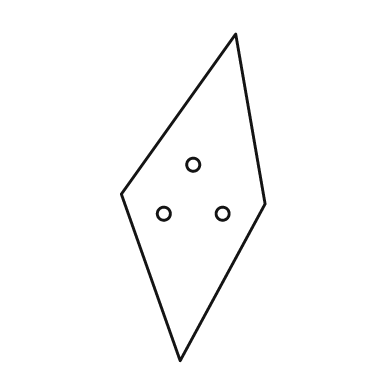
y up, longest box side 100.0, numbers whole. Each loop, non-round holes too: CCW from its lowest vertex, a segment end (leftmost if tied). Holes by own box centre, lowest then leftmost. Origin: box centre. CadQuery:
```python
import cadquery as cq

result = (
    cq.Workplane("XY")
    .moveTo(-4.0, -50.0)
    .lineTo(22.0, -2.0)
    .lineTo(13.0, 50.0)
    .lineTo(-22.0, 1.0)
    .close()
    .moveTo(-9.0, -5.0)
    .circle(2.0)
    .moveTo(9.0, -5.0)
    .circle(2.0)
    .moveTo(0.0, 10.0)
    .circle(2.0)
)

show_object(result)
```